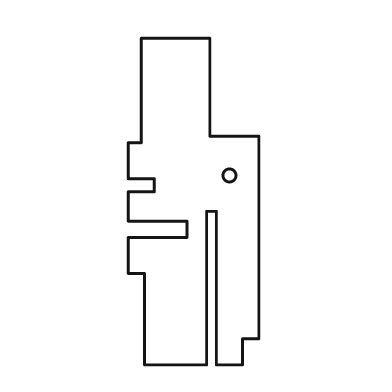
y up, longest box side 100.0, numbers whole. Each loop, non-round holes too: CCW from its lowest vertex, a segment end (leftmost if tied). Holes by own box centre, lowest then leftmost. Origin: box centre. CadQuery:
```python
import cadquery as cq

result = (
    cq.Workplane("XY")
    .moveTo(-15.0, -50.0)
    .lineTo(4.0, -50.0)
    .lineTo(4.0, -3.0)
    .lineTo(7.0, -3.0)
    .lineTo(7.0, -50.0)
    .lineTo(15.0, -50.0)
    .lineTo(15.0, -42.0)
    .lineTo(20.0, -42.0)
    .lineTo(20.0, 20.0)
    .lineTo(5.0, 20.0)
    .lineTo(5.0, 50.0)
    .lineTo(-16.0, 50.0)
    .lineTo(-16.0, 18.0)
    .lineTo(-20.0, 18.0)
    .lineTo(-20.0, 7.0)
    .lineTo(-12.0, 7.0)
    .lineTo(-12.0, 3.0)
    .lineTo(-20.0, 3.0)
    .lineTo(-20.0, -6.0)
    .lineTo(-2.0, -6.0)
    .lineTo(-2.0, -11.0)
    .lineTo(-20.0, -11.0)
    .lineTo(-20.0, -22.0)
    .lineTo(-15.0, -22.0)
    .close()
    .moveTo(11.0, 8.0)
    .circle(2.0)
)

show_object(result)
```